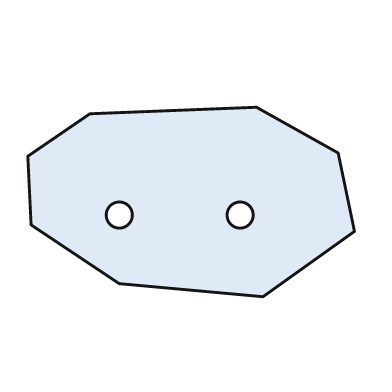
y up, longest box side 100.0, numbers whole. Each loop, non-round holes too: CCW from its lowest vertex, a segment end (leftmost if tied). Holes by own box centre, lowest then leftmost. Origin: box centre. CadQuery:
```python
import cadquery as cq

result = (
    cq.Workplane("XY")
    .moveTo(22.0, -29.0)
    .lineTo(50.0, -9.0)
    .lineTo(45.0, 15.0)
    .lineTo(20.0, 29.0)
    .lineTo(-31.0, 27.0)
    .lineTo(-50.0, 14.0)
    .lineTo(-49.0, -7.0)
    .lineTo(-22.0, -25.0)
    .close()
    .moveTo(-22.0, -4.0)
    .circle(4.0)
    .moveTo(15.0, -4.0)
    .circle(4.0)
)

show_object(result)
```